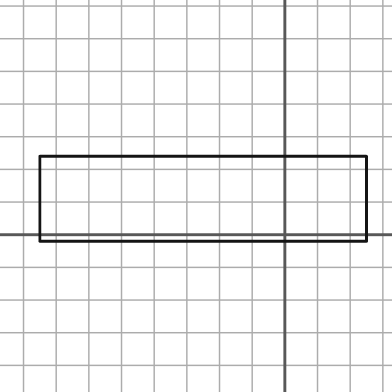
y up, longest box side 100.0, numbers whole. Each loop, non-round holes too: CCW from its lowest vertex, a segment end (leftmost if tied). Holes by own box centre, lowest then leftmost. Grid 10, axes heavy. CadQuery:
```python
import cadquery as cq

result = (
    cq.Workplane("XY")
    .moveTo(-75.0, -2.0)
    .lineTo(25.0, -2.0)
    .lineTo(25.0, 24.0)
    .lineTo(-75.0, 24.0)
    .close()
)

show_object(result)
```